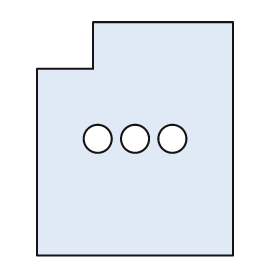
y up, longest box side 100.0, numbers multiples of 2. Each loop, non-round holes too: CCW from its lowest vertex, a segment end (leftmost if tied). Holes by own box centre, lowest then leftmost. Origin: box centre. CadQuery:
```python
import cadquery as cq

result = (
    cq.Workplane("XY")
    .moveTo(-42.0, -50.0)
    .lineTo(42.0, -50.0)
    .lineTo(42.0, 50.0)
    .lineTo(-18.0, 50.0)
    .lineTo(-18.0, 30.0)
    .lineTo(-42.0, 30.0)
    .close()
    .moveTo(-16.0, 0.0)
    .circle(6.0)
    .moveTo(0.0, 0.0)
    .circle(6.0)
    .moveTo(16.0, 0.0)
    .circle(6.0)
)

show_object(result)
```